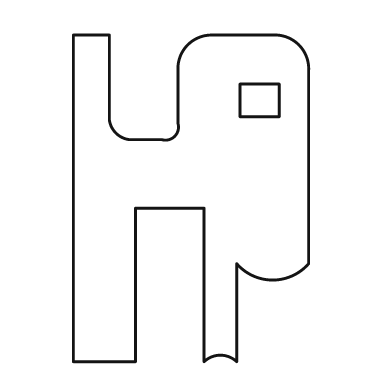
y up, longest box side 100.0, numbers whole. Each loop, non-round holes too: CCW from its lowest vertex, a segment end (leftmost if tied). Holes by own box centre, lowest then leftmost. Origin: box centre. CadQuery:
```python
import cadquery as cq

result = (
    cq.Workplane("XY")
    .moveTo(-36.0, -50.0)
    .lineTo(-17.0, -50.0)
    .lineTo(-17.0, -3.0)
    .lineTo(4.0, -3.0)
    .lineTo(4.0, -50.0)
    .threePointArc((9.0, -48.0), (14.0, -50.0))
    .lineTo(14.0, -20.0)
    .threePointArc((25.0, -25.0), (36.0, -20.0))
    .lineTo(36.0, 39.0)
    .threePointArc((33.0, 47.0), (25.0, 50.0))
    .lineTo(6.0, 50.0)
    .threePointArc((-1.0, 47.0), (-4.0, 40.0))
    .lineTo(-4.0, 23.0)
    .threePointArc((-5.0, 19.0), (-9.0, 18.0))
    .lineTo(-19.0, 18.0)
    .threePointArc((-23.0, 20.0), (-25.0, 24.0))
    .lineTo(-25.0, 50.0)
    .lineTo(-36.0, 50.0)
    .close()
    .moveTo(15.0, 25.0)
    .lineTo(27.0, 25.0)
    .lineTo(27.0, 35.0)
    .lineTo(15.0, 35.0)
    .close()
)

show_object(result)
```